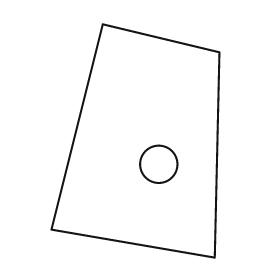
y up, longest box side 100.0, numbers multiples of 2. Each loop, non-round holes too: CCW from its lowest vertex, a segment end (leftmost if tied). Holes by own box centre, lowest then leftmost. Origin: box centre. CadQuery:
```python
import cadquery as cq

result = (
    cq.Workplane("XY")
    .moveTo(34.0, -50.0)
    .lineTo(36.0, 38.0)
    .lineTo(-14.0, 50.0)
    .lineTo(-36.0, -38.0)
    .close()
    .moveTo(10.0, -10.0)
    .circle(8.0)
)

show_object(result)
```